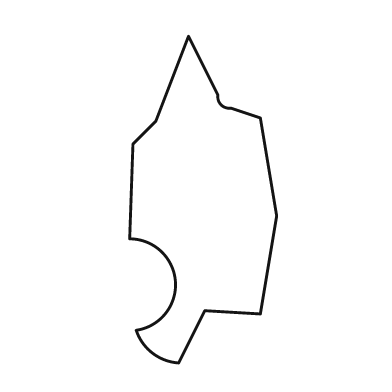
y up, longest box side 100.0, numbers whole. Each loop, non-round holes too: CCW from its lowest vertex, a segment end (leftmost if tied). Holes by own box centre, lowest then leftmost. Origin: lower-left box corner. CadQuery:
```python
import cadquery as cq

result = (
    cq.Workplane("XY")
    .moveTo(15.0, 0.0)
    .lineTo(23.0, 16.0)
    .lineTo(40.0, 15.0)
    .lineTo(45.0, 45.0)
    .lineTo(40.0, 75.0)
    .lineTo(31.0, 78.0)
    .threePointArc((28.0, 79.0), (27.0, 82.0))
    .lineTo(18.0, 100.0)
    .lineTo(8.0, 74.0)
    .lineTo(1.0, 67.0)
    .lineTo(0.0, 38.0)
    .threePointArc((14.0, 25.0), (2.0, 10.0))
    .threePointArc((7.0, 3.0), (15.0, 0.0))
    .close()
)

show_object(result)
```